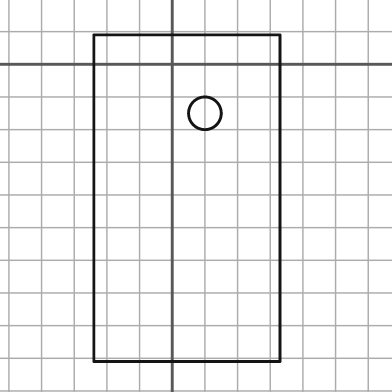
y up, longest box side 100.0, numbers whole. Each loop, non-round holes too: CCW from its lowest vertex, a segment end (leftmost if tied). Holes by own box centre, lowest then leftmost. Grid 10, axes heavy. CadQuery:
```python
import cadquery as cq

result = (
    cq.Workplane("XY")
    .moveTo(-24.0, -91.0)
    .lineTo(33.0, -91.0)
    .lineTo(33.0, 9.0)
    .lineTo(-24.0, 9.0)
    .close()
    .moveTo(10.0, -15.0)
    .circle(5.0)
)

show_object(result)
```